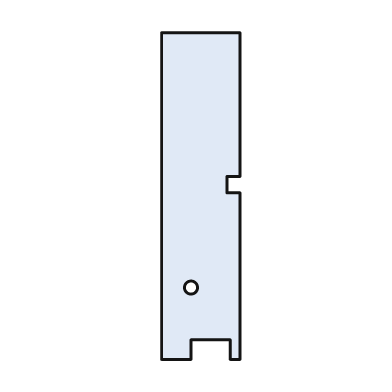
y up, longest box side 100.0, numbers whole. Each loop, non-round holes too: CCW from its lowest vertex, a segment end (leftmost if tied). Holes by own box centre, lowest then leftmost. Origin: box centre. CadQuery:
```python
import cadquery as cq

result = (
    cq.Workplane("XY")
    .moveTo(-12.0, -50.0)
    .lineTo(-3.0, -50.0)
    .lineTo(-3.0, -44.0)
    .lineTo(9.0, -44.0)
    .lineTo(9.0, -50.0)
    .lineTo(12.0, -50.0)
    .lineTo(12.0, 1.0)
    .lineTo(8.0, 1.0)
    .lineTo(8.0, 6.0)
    .lineTo(12.0, 6.0)
    .lineTo(12.0, 50.0)
    .lineTo(-12.0, 50.0)
    .close()
    .moveTo(-3.0, -28.0)
    .circle(2.0)
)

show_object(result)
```